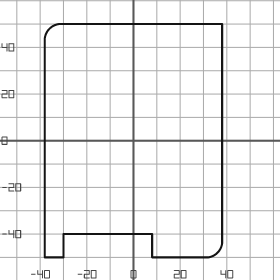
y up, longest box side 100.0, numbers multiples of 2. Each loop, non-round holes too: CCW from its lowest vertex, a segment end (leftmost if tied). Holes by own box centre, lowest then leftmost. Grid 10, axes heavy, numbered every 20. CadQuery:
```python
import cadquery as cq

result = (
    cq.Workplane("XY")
    .moveTo(-38.0, -50.0)
    .lineTo(-30.0, -50.0)
    .lineTo(-30.0, -40.0)
    .lineTo(8.0, -40.0)
    .lineTo(8.0, -50.0)
    .lineTo(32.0, -50.0)
    .threePointArc((36.0, -48.0), (38.0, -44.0))
    .lineTo(38.0, 50.0)
    .lineTo(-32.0, 50.0)
    .threePointArc((-36.0, 48.0), (-38.0, 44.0))
    .close()
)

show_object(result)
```